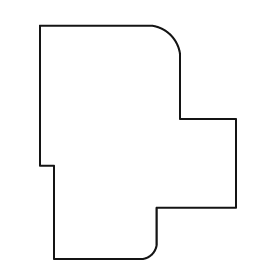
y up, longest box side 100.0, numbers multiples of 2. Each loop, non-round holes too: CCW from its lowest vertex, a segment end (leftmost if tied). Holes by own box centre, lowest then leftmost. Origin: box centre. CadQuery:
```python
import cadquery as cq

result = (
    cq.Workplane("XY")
    .moveTo(-36.0, -50.0)
    .lineTo(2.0, -50.0)
    .threePointArc((6.0, -48.0), (8.0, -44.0))
    .lineTo(8.0, -28.0)
    .lineTo(42.0, -28.0)
    .lineTo(42.0, 10.0)
    .lineTo(18.0, 10.0)
    .lineTo(18.0, 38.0)
    .threePointArc((14.0, 46.0), (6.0, 50.0))
    .lineTo(-42.0, 50.0)
    .lineTo(-42.0, -10.0)
    .lineTo(-36.0, -10.0)
    .close()
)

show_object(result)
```